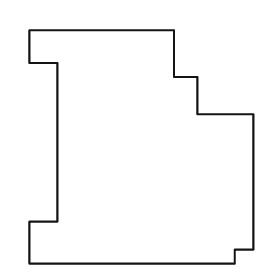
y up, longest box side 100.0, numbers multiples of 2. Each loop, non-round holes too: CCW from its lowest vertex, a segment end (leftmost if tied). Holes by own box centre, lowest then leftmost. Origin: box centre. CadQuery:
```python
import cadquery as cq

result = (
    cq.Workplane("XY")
    .moveTo(-48.0, -50.0)
    .lineTo(40.0, -50.0)
    .lineTo(40.0, -44.0)
    .lineTo(48.0, -44.0)
    .lineTo(48.0, 14.0)
    .lineTo(24.0, 14.0)
    .lineTo(24.0, 30.0)
    .lineTo(14.0, 30.0)
    .lineTo(14.0, 50.0)
    .lineTo(-48.0, 50.0)
    .lineTo(-48.0, 36.0)
    .lineTo(-36.0, 36.0)
    .lineTo(-36.0, -32.0)
    .lineTo(-48.0, -32.0)
    .close()
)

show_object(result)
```